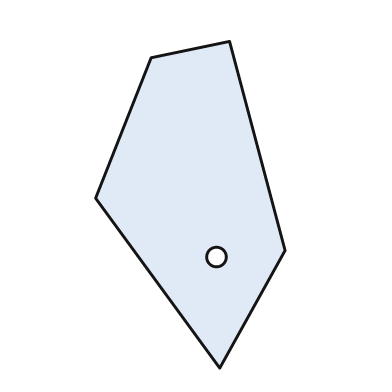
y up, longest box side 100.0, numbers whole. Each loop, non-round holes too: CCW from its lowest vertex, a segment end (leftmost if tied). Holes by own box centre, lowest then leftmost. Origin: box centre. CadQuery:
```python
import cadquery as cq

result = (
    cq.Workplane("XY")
    .moveTo(9.0, -50.0)
    .lineTo(29.0, -14.0)
    .lineTo(12.0, 50.0)
    .lineTo(-12.0, 45.0)
    .lineTo(-29.0, 2.0)
    .close()
    .moveTo(8.0, -16.0)
    .circle(3.0)
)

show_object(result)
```